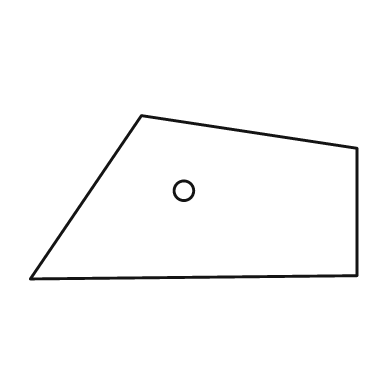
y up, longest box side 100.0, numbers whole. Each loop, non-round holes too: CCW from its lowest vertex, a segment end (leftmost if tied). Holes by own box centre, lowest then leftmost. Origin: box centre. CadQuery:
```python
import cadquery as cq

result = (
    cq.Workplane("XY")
    .moveTo(-50.0, -25.0)
    .lineTo(50.0, -24.0)
    .lineTo(50.0, 15.0)
    .lineTo(-16.0, 25.0)
    .close()
    .moveTo(-3.0, 2.0)
    .circle(3.0)
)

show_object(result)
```